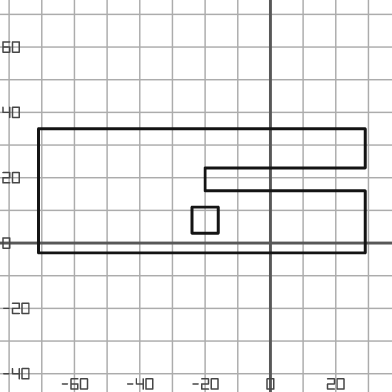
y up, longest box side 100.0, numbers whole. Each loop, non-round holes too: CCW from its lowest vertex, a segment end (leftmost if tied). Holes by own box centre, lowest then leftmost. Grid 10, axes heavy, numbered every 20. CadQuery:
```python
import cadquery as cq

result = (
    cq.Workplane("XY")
    .moveTo(-71.0, -3.0)
    .lineTo(29.0, -3.0)
    .lineTo(29.0, 16.0)
    .lineTo(-20.0, 16.0)
    .lineTo(-20.0, 23.0)
    .lineTo(29.0, 23.0)
    .lineTo(29.0, 35.0)
    .lineTo(-71.0, 35.0)
    .close()
    .moveTo(-24.0, 3.0)
    .lineTo(-16.0, 3.0)
    .lineTo(-16.0, 11.0)
    .lineTo(-24.0, 11.0)
    .close()
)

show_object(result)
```